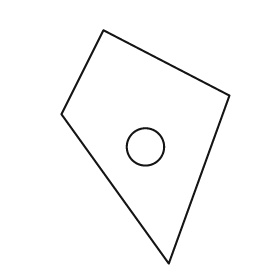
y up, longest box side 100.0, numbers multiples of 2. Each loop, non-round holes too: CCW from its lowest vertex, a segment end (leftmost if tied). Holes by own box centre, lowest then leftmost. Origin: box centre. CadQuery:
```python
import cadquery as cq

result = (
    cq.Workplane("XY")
    .moveTo(10.0, -50.0)
    .lineTo(36.0, 22.0)
    .lineTo(-18.0, 50.0)
    .lineTo(-36.0, 14.0)
    .close()
    .moveTo(0.0, 0.0)
    .circle(8.0)
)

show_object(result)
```